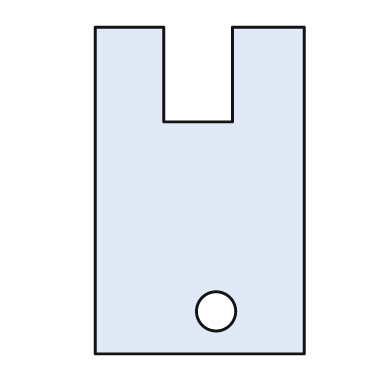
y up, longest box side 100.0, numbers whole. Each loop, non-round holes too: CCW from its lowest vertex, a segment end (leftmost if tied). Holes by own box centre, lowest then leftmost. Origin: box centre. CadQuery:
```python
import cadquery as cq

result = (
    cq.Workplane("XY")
    .moveTo(-32.0, -50.0)
    .lineTo(32.0, -50.0)
    .lineTo(32.0, 50.0)
    .lineTo(10.0, 50.0)
    .lineTo(10.0, 21.0)
    .lineTo(-11.0, 21.0)
    .lineTo(-11.0, 50.0)
    .lineTo(-32.0, 50.0)
    .close()
    .moveTo(5.0, -37.0)
    .circle(6.0)
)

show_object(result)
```